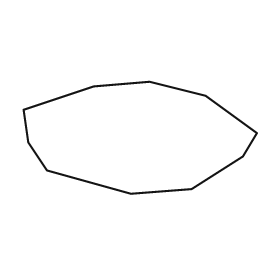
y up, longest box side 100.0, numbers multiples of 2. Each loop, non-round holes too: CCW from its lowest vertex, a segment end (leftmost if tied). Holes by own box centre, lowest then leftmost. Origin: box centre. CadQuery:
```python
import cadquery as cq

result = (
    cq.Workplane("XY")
    .moveTo(-4.0, -24.0)
    .lineTo(22.0, -22.0)
    .lineTo(44.0, -8.0)
    .lineTo(50.0, 2.0)
    .lineTo(28.0, 18.0)
    .lineTo(4.0, 24.0)
    .lineTo(-20.0, 22.0)
    .lineTo(-50.0, 12.0)
    .lineTo(-48.0, -2.0)
    .lineTo(-40.0, -14.0)
    .close()
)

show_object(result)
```